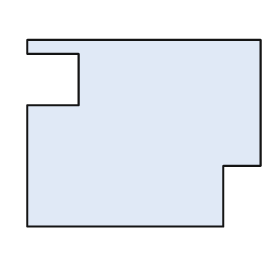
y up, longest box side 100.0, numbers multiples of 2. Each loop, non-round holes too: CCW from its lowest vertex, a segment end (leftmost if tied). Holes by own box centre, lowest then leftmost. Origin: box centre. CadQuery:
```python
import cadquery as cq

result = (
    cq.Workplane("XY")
    .moveTo(-50.0, -40.0)
    .lineTo(34.0, -40.0)
    .lineTo(34.0, -14.0)
    .lineTo(50.0, -14.0)
    .lineTo(50.0, 40.0)
    .lineTo(-50.0, 40.0)
    .lineTo(-50.0, 34.0)
    .lineTo(-28.0, 34.0)
    .lineTo(-28.0, 12.0)
    .lineTo(-50.0, 12.0)
    .close()
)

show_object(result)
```